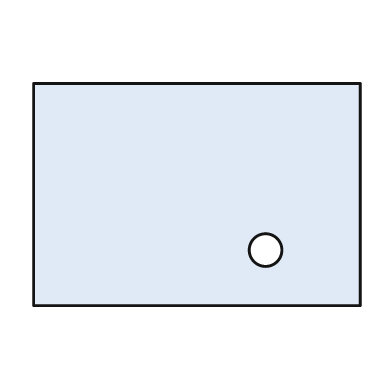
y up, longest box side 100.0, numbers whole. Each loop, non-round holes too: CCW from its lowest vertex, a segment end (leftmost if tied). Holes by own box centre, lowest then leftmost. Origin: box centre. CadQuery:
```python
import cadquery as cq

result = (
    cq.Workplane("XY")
    .moveTo(-50.0, -34.0)
    .lineTo(50.0, -34.0)
    .lineTo(50.0, 34.0)
    .lineTo(-50.0, 34.0)
    .close()
    .moveTo(21.0, -17.0)
    .circle(5.0)
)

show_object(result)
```